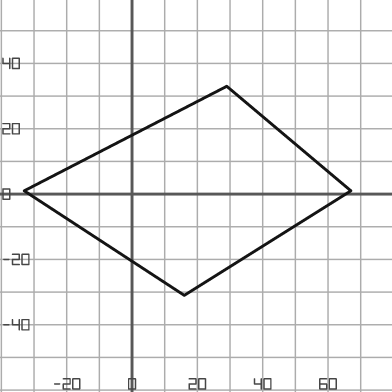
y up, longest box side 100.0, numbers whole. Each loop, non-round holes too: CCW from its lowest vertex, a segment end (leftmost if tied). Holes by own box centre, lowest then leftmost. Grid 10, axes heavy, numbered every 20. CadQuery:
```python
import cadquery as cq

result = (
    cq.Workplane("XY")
    .moveTo(16.0, -31.0)
    .lineTo(67.0, 1.0)
    .lineTo(29.0, 33.0)
    .lineTo(-33.0, 1.0)
    .close()
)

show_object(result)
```